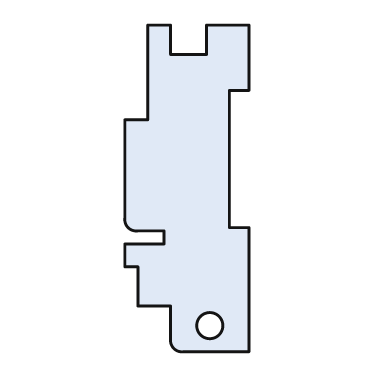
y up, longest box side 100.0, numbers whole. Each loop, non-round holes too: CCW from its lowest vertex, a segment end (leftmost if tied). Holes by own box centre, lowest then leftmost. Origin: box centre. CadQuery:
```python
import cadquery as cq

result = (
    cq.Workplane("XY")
    .moveTo(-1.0, -50.0)
    .lineTo(19.0, -50.0)
    .lineTo(19.0, -12.0)
    .lineTo(13.0, -12.0)
    .lineTo(13.0, 30.0)
    .lineTo(19.0, 30.0)
    .lineTo(19.0, 50.0)
    .lineTo(6.0, 50.0)
    .lineTo(6.0, 41.0)
    .lineTo(-5.0, 41.0)
    .lineTo(-5.0, 50.0)
    .lineTo(-12.0, 50.0)
    .lineTo(-12.0, 21.0)
    .lineTo(-19.0, 21.0)
    .lineTo(-19.0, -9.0)
    .threePointArc((-18.0, -12.0), (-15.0, -13.0))
    .lineTo(-7.0, -13.0)
    .lineTo(-7.0, -17.0)
    .lineTo(-19.0, -17.0)
    .lineTo(-19.0, -24.0)
    .lineTo(-15.0, -24.0)
    .lineTo(-15.0, -36.0)
    .lineTo(-5.0, -36.0)
    .lineTo(-5.0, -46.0)
    .threePointArc((-4.0, -49.0), (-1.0, -50.0))
    .close()
    .moveTo(7.0, -42.0)
    .circle(4.0)
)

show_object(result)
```